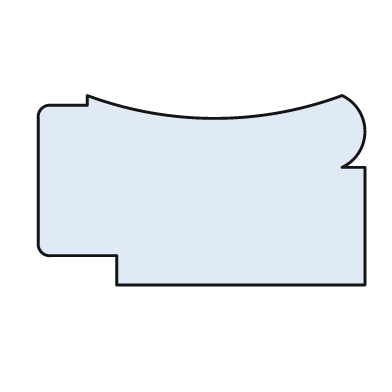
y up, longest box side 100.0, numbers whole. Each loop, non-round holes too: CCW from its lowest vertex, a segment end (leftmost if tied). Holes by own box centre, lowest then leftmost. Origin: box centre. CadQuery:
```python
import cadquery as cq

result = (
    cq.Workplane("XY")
    .moveTo(-26.0, -29.0)
    .lineTo(50.0, -29.0)
    .lineTo(50.0, 7.0)
    .lineTo(43.0, 7.0)
    .threePointArc((50.0, 18.0), (43.0, 29.0))
    .threePointArc((4.0, 22.0), (-35.0, 29.0))
    .lineTo(-35.0, 26.0)
    .lineTo(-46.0, 26.0)
    .threePointArc((-49.0, 25.0), (-50.0, 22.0))
    .lineTo(-50.0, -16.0)
    .threePointArc((-49.0, -19.0), (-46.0, -20.0))
    .lineTo(-26.0, -20.0)
    .close()
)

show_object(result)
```